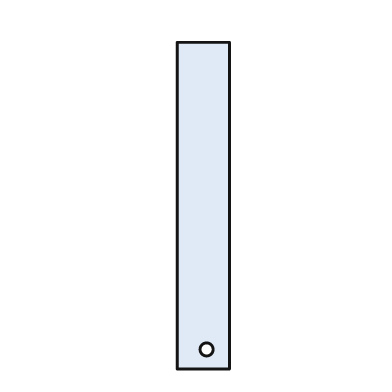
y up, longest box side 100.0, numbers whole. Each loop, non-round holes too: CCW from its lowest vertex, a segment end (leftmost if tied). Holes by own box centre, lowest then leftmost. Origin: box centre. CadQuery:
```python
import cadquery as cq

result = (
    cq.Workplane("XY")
    .moveTo(-8.0, -50.0)
    .lineTo(8.0, -50.0)
    .lineTo(8.0, 50.0)
    .lineTo(-8.0, 50.0)
    .close()
    .moveTo(1.0, -44.0)
    .circle(2.0)
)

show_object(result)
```